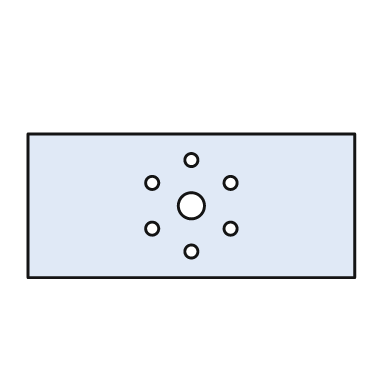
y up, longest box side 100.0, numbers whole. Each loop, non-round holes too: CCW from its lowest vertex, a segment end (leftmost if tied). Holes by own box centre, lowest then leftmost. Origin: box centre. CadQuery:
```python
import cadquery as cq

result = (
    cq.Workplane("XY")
    .moveTo(-50.0, -22.0)
    .lineTo(50.0, -22.0)
    .lineTo(50.0, 22.0)
    .lineTo(-50.0, 22.0)
    .close()
    .moveTo(0.0, -14.0)
    .circle(2.0)
    .moveTo(-12.0, -7.0)
    .circle(2.0)
    .moveTo(12.0, -7.0)
    .circle(2.0)
    .moveTo(0.0, 0.0)
    .circle(4.0)
    .moveTo(-12.0, 7.0)
    .circle(2.0)
    .moveTo(12.0, 7.0)
    .circle(2.0)
    .moveTo(0.0, 14.0)
    .circle(2.0)
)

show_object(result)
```